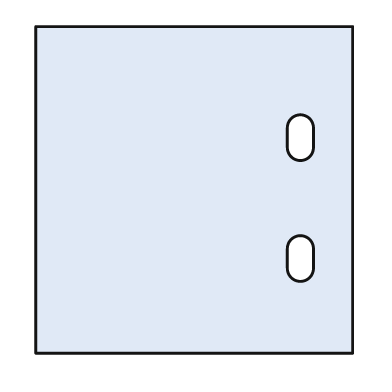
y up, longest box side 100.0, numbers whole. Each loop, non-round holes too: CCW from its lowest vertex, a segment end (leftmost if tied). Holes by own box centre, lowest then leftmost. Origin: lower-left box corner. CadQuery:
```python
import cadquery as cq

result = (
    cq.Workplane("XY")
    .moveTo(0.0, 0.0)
    .lineTo(97.0, 0.0)
    .lineTo(97.0, 100.0)
    .lineTo(0.0, 100.0)
    .close()
    .moveTo(77.0, 26.0)
    .threePointArc((81.0, 22.0), (85.0, 26.0))
    .lineTo(85.0, 32.0)
    .threePointArc((81.0, 36.0), (77.0, 32.0))
    .close()
    .moveTo(77.0, 63.0)
    .threePointArc((81.0, 59.0), (85.0, 63.0))
    .lineTo(85.0, 69.0)
    .threePointArc((81.0, 73.0), (77.0, 69.0))
    .close()
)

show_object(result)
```